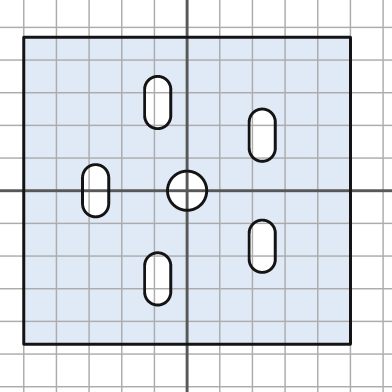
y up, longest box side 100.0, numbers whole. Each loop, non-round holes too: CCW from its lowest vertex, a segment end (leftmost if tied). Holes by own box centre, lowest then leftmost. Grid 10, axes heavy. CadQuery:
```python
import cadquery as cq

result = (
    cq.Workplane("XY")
    .moveTo(-50.0, -47.0)
    .lineTo(50.0, -47.0)
    .lineTo(50.0, 47.0)
    .lineTo(-50.0, 47.0)
    .close()
    .moveTo(-13.0, -31.0)
    .threePointArc((-9.0, -35.0), (-5.0, -31.0))
    .lineTo(-5.0, -23.0)
    .threePointArc((-9.0, -19.0), (-13.0, -23.0))
    .close()
    .moveTo(19.0, -21.0)
    .threePointArc((23.0, -25.0), (27.0, -21.0))
    .lineTo(27.0, -13.0)
    .threePointArc((23.0, -9.0), (19.0, -13.0))
    .close()
    .moveTo(-32.0, -4.0)
    .threePointArc((-28.0, -8.0), (-24.0, -4.0))
    .lineTo(-24.0, 4.0)
    .threePointArc((-28.0, 8.0), (-32.0, 4.0))
    .close()
    .moveTo(0.0, 0.0)
    .circle(6.0)
    .moveTo(19.0, 13.0)
    .threePointArc((23.0, 9.0), (27.0, 13.0))
    .lineTo(27.0, 21.0)
    .threePointArc((23.0, 25.0), (19.0, 21.0))
    .close()
    .moveTo(-13.0, 23.0)
    .threePointArc((-9.0, 19.0), (-5.0, 23.0))
    .lineTo(-5.0, 31.0)
    .threePointArc((-9.0, 35.0), (-13.0, 31.0))
    .close()
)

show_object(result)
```